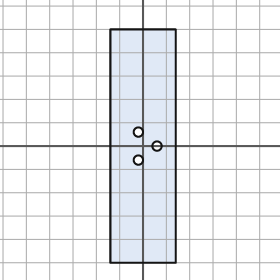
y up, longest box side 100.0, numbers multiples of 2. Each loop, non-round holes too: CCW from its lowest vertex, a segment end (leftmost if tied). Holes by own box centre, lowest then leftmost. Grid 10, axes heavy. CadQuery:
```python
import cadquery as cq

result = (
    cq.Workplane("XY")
    .moveTo(-14.0, -50.0)
    .lineTo(14.0, -50.0)
    .lineTo(14.0, 50.0)
    .lineTo(-14.0, 50.0)
    .close()
    .moveTo(-2.0, -6.0)
    .circle(2.0)
    .moveTo(6.0, 0.0)
    .circle(2.0)
    .moveTo(-2.0, 6.0)
    .circle(2.0)
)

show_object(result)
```